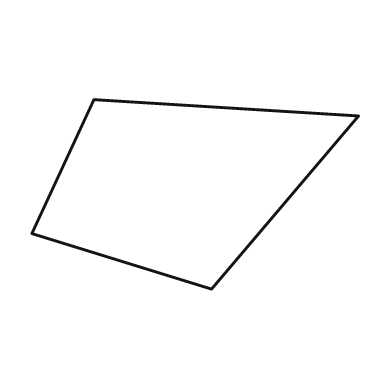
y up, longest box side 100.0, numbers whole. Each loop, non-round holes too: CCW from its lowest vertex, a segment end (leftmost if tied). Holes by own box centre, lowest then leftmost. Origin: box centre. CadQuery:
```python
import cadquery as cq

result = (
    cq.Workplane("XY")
    .moveTo(5.0, -29.0)
    .lineTo(50.0, 24.0)
    .lineTo(-31.0, 29.0)
    .lineTo(-50.0, -12.0)
    .close()
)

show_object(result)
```